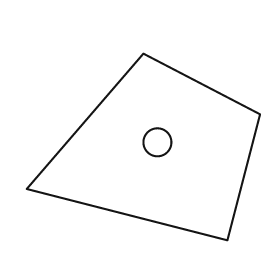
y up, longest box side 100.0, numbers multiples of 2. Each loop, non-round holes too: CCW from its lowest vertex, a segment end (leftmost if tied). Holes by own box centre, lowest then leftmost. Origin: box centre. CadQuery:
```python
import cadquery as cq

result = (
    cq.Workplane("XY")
    .moveTo(36.0, -40.0)
    .lineTo(50.0, 14.0)
    .lineTo(0.0, 40.0)
    .lineTo(-50.0, -18.0)
    .close()
    .moveTo(6.0, 2.0)
    .circle(6.0)
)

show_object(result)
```